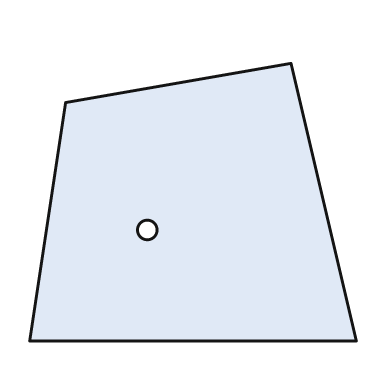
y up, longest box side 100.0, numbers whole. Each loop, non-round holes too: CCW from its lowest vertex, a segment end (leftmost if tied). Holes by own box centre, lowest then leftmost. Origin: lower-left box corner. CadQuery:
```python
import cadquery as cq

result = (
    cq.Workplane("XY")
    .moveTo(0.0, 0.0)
    .lineTo(100.0, 0.0)
    .lineTo(80.0, 85.0)
    .lineTo(11.0, 73.0)
    .close()
    .moveTo(36.0, 34.0)
    .circle(3.0)
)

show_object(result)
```